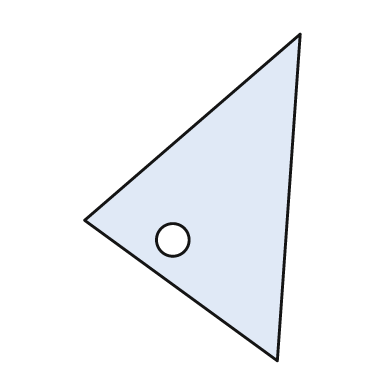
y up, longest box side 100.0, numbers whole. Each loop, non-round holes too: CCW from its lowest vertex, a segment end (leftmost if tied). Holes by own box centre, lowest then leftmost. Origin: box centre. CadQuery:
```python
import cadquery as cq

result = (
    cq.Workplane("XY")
    .moveTo(26.0, -50.0)
    .lineTo(33.0, 50.0)
    .lineTo(-33.0, -7.0)
    .close()
    .moveTo(-6.0, -13.0)
    .circle(5.0)
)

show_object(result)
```